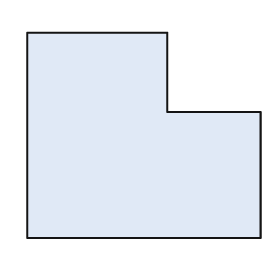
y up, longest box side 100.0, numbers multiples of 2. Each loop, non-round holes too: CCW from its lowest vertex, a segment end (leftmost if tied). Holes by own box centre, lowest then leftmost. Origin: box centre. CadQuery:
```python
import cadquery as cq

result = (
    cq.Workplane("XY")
    .moveTo(-50.0, -44.0)
    .lineTo(50.0, -44.0)
    .lineTo(50.0, 10.0)
    .lineTo(10.0, 10.0)
    .lineTo(10.0, 44.0)
    .lineTo(-50.0, 44.0)
    .close()
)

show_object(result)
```